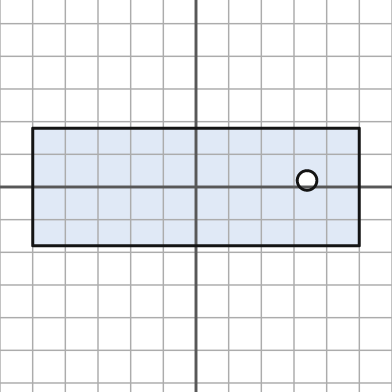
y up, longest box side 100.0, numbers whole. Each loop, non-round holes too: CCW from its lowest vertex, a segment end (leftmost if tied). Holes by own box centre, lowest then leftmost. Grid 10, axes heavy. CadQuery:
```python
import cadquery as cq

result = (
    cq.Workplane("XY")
    .moveTo(-50.0, -18.0)
    .lineTo(50.0, -18.0)
    .lineTo(50.0, 18.0)
    .lineTo(-50.0, 18.0)
    .close()
    .moveTo(34.0, 2.0)
    .circle(3.0)
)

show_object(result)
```